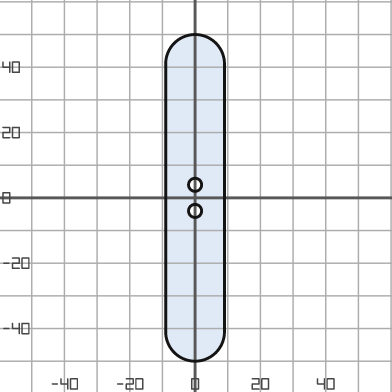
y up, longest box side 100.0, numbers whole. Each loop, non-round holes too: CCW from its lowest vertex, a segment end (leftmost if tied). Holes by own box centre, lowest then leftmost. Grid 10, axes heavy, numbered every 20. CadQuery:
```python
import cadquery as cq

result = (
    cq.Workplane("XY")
    .moveTo(-9.0, -41.0)
    .threePointArc((0.0, -50.0), (9.0, -41.0))
    .lineTo(9.0, 41.0)
    .threePointArc((0.0, 50.0), (-9.0, 41.0))
    .close()
    .moveTo(0.0, -4.0)
    .circle(2.0)
    .moveTo(0.0, 4.0)
    .circle(2.0)
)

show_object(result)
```